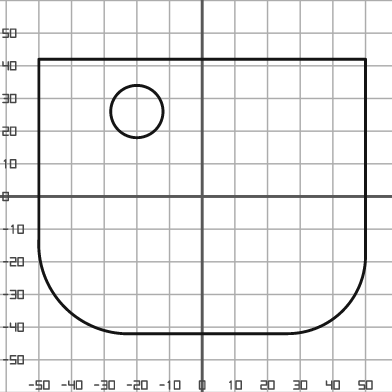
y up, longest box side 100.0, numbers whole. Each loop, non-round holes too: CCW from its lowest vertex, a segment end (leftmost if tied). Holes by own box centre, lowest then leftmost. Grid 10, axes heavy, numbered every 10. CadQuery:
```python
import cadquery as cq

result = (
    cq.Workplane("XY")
    .moveTo(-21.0, -42.0)
    .lineTo(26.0, -42.0)
    .threePointArc((43.0, -35.0), (50.0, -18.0))
    .lineTo(50.0, 42.0)
    .lineTo(-50.0, 42.0)
    .lineTo(-50.0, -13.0)
    .threePointArc((-42.0, -34.0), (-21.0, -42.0))
    .close()
    .moveTo(-20.0, 26.0)
    .circle(8.0)
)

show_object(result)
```